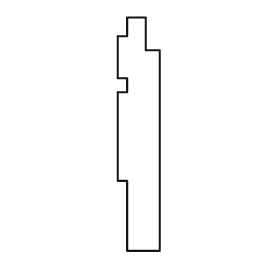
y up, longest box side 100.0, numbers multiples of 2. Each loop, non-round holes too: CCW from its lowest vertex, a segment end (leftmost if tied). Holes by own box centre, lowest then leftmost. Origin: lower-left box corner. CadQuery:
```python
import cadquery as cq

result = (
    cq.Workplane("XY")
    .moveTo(4.0, 0.0)
    .lineTo(18.0, 0.0)
    .lineTo(18.0, 86.0)
    .lineTo(12.0, 86.0)
    .lineTo(12.0, 100.0)
    .lineTo(4.0, 100.0)
    .lineTo(4.0, 92.0)
    .lineTo(0.0, 92.0)
    .lineTo(0.0, 74.0)
    .lineTo(4.0, 74.0)
    .lineTo(4.0, 68.0)
    .lineTo(0.0, 68.0)
    .lineTo(0.0, 30.0)
    .lineTo(4.0, 30.0)
    .close()
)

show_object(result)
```